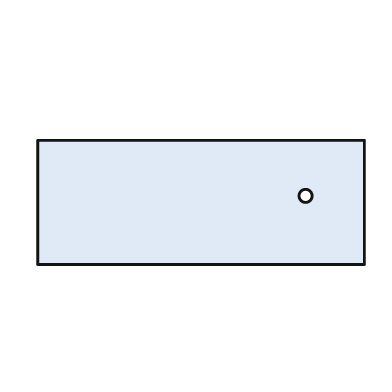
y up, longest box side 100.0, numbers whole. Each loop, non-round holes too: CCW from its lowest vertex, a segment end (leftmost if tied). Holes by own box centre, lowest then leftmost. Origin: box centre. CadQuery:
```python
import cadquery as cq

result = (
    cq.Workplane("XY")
    .moveTo(-50.0, -19.0)
    .lineTo(50.0, -19.0)
    .lineTo(50.0, 19.0)
    .lineTo(-50.0, 19.0)
    .close()
    .moveTo(32.0, 2.0)
    .circle(2.0)
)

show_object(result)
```